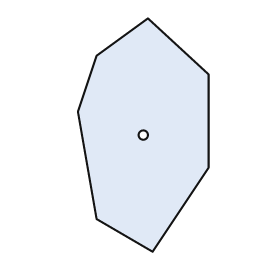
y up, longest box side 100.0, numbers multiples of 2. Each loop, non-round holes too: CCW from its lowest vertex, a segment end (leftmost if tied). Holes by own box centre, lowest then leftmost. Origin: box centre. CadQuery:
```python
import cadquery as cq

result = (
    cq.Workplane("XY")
    .moveTo(4.0, -50.0)
    .lineTo(28.0, -14.0)
    .lineTo(28.0, 26.0)
    .lineTo(2.0, 50.0)
    .lineTo(-20.0, 34.0)
    .lineTo(-28.0, 10.0)
    .lineTo(-20.0, -36.0)
    .close()
    .moveTo(0.0, 0.0)
    .circle(2.0)
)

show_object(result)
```